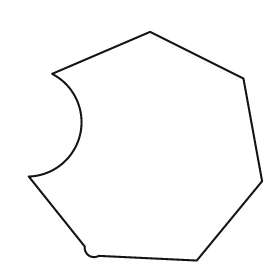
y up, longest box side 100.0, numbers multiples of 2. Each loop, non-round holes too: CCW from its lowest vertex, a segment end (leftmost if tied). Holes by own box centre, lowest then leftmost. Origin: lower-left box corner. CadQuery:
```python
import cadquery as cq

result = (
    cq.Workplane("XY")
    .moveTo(72.0, 0.0)
    .lineTo(100.0, 34.0)
    .lineTo(92.0, 78.0)
    .lineTo(52.0, 98.0)
    .lineTo(10.0, 80.0)
    .threePointArc((22.0, 54.0), (0.0, 36.0))
    .lineTo(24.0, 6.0)
    .threePointArc((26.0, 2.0), (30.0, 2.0))
    .close()
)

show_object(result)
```